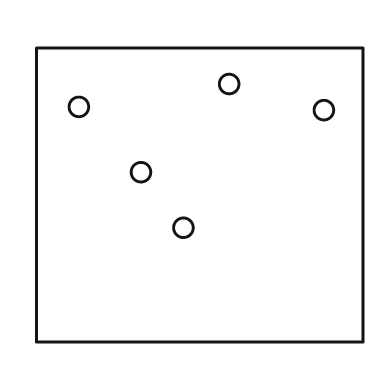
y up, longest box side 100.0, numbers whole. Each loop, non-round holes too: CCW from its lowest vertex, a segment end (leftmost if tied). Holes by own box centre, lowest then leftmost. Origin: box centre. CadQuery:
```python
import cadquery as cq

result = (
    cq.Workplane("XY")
    .moveTo(-50.0, -45.0)
    .lineTo(50.0, -45.0)
    .lineTo(50.0, 45.0)
    .lineTo(-50.0, 45.0)
    .close()
    .moveTo(-5.0, -10.0)
    .circle(3.0)
    .moveTo(-18.0, 7.0)
    .circle(3.0)
    .moveTo(38.0, 26.0)
    .circle(3.0)
    .moveTo(-37.0, 27.0)
    .circle(3.0)
    .moveTo(9.0, 34.0)
    .circle(3.0)
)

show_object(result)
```